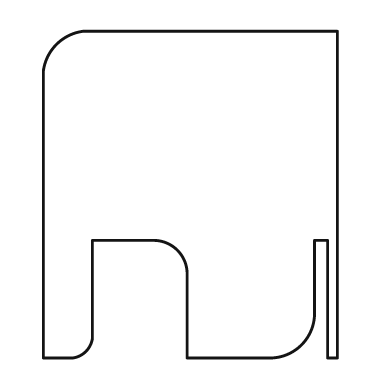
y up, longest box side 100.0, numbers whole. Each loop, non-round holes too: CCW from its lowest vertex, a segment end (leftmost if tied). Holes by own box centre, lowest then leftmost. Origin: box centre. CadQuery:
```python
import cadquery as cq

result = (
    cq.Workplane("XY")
    .moveTo(-45.0, -50.0)
    .lineTo(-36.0, -50.0)
    .threePointArc((-32.0, -48.0), (-30.0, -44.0))
    .lineTo(-30.0, -14.0)
    .lineTo(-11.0, -14.0)
    .threePointArc((-4.0, -17.0), (-1.0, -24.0))
    .lineTo(-1.0, -50.0)
    .lineTo(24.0, -50.0)
    .threePointArc((34.0, -46.0), (38.0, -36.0))
    .lineTo(38.0, -14.0)
    .lineTo(42.0, -14.0)
    .lineTo(42.0, -50.0)
    .lineTo(45.0, -50.0)
    .lineTo(45.0, 50.0)
    .lineTo(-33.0, 50.0)
    .threePointArc((-41.0, 46.0), (-45.0, 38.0))
    .close()
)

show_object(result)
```